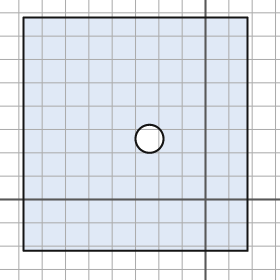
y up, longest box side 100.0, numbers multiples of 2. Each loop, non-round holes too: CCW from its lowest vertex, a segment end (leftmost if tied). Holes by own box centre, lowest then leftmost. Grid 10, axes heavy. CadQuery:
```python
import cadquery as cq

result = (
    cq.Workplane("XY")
    .moveTo(-78.0, -22.0)
    .lineTo(18.0, -22.0)
    .lineTo(18.0, 78.0)
    .lineTo(-78.0, 78.0)
    .close()
    .moveTo(-24.0, 26.0)
    .circle(6.0)
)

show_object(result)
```